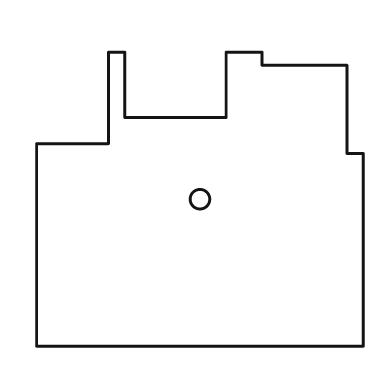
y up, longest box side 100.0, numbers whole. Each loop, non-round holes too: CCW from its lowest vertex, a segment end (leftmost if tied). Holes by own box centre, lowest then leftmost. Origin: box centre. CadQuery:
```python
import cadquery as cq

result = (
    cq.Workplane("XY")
    .moveTo(-50.0, -45.0)
    .lineTo(50.0, -45.0)
    .lineTo(50.0, 14.0)
    .lineTo(45.0, 14.0)
    .lineTo(45.0, 41.0)
    .lineTo(19.0, 41.0)
    .lineTo(19.0, 45.0)
    .lineTo(8.0, 45.0)
    .lineTo(8.0, 25.0)
    .lineTo(-23.0, 25.0)
    .lineTo(-23.0, 45.0)
    .lineTo(-28.0, 45.0)
    .lineTo(-28.0, 17.0)
    .lineTo(-50.0, 17.0)
    .close()
    .moveTo(0.0, 0.0)
    .circle(3.0)
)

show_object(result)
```